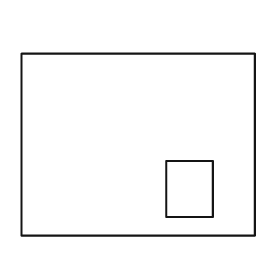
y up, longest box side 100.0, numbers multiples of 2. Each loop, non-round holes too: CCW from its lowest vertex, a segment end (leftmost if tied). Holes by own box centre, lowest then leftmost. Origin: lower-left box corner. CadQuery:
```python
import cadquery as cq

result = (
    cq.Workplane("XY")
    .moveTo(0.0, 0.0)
    .lineTo(100.0, 0.0)
    .lineTo(100.0, 78.0)
    .lineTo(0.0, 78.0)
    .close()
    .moveTo(62.0, 8.0)
    .lineTo(82.0, 8.0)
    .lineTo(82.0, 32.0)
    .lineTo(62.0, 32.0)
    .close()
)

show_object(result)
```